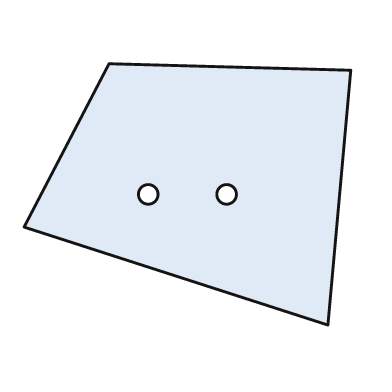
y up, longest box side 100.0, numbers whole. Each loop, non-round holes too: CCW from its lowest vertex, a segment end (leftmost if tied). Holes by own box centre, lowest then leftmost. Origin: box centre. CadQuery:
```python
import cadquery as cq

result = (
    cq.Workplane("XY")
    .moveTo(43.0, -40.0)
    .lineTo(50.0, 38.0)
    .lineTo(-24.0, 40.0)
    .lineTo(-50.0, -10.0)
    .close()
    .moveTo(-12.0, 0.0)
    .circle(3.0)
    .moveTo(12.0, 0.0)
    .circle(3.0)
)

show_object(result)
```